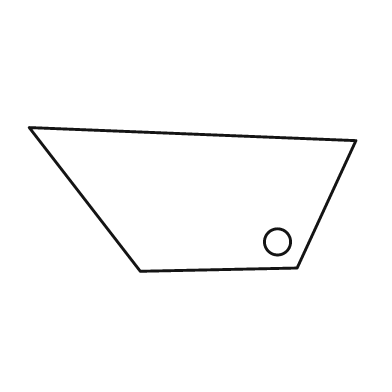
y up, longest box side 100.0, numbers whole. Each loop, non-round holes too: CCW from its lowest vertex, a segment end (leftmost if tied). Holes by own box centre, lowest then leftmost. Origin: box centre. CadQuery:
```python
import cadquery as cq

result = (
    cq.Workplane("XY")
    .moveTo(-16.0, -22.0)
    .lineTo(32.0, -21.0)
    .lineTo(50.0, 18.0)
    .lineTo(-50.0, 22.0)
    .close()
    .moveTo(26.0, -13.0)
    .circle(4.0)
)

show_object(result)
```